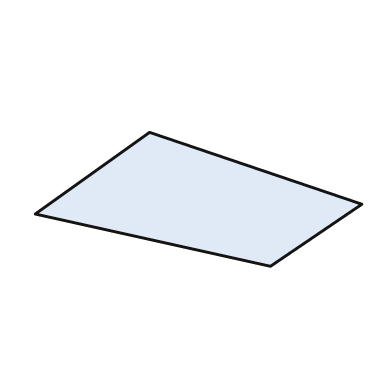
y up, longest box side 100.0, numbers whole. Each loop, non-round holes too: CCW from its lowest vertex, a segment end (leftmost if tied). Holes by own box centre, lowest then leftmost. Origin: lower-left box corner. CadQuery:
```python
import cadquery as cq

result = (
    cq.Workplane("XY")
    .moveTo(72.0, 0.0)
    .lineTo(100.0, 19.0)
    .lineTo(35.0, 41.0)
    .lineTo(0.0, 16.0)
    .close()
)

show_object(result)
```